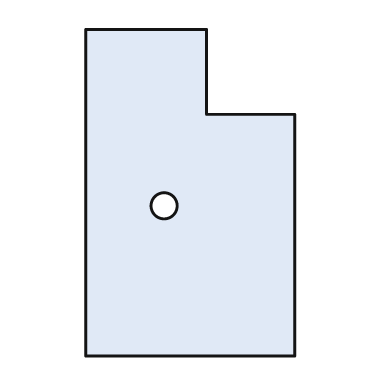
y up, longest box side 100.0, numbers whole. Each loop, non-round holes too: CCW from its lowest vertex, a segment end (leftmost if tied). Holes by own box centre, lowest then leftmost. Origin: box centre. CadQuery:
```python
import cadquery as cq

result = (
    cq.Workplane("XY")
    .moveTo(-32.0, -50.0)
    .lineTo(32.0, -50.0)
    .lineTo(32.0, 24.0)
    .lineTo(5.0, 24.0)
    .lineTo(5.0, 50.0)
    .lineTo(-32.0, 50.0)
    .close()
    .moveTo(-8.0, -4.0)
    .circle(4.0)
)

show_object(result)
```